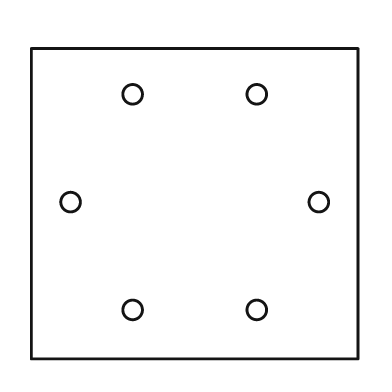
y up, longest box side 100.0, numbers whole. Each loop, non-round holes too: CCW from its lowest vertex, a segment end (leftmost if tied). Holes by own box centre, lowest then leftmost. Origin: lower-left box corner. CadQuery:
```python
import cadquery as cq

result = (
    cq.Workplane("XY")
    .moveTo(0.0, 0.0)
    .lineTo(100.0, 0.0)
    .lineTo(100.0, 95.0)
    .lineTo(0.0, 95.0)
    .close()
    .moveTo(31.0, 15.0)
    .circle(3.0)
    .moveTo(69.0, 15.0)
    .circle(3.0)
    .moveTo(12.0, 48.0)
    .circle(3.0)
    .moveTo(88.0, 48.0)
    .circle(3.0)
    .moveTo(31.0, 81.0)
    .circle(3.0)
    .moveTo(69.0, 81.0)
    .circle(3.0)
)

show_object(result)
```